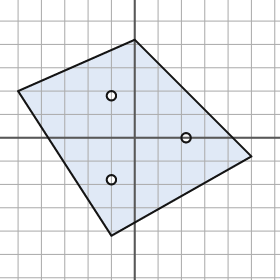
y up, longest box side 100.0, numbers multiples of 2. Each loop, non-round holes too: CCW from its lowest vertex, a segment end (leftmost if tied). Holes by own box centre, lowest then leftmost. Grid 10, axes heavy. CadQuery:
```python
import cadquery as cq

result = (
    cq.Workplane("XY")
    .moveTo(-10.0, -42.0)
    .lineTo(50.0, -8.0)
    .lineTo(0.0, 42.0)
    .lineTo(-50.0, 20.0)
    .close()
    .moveTo(-10.0, -18.0)
    .circle(2.0)
    .moveTo(22.0, 0.0)
    .circle(2.0)
    .moveTo(-10.0, 18.0)
    .circle(2.0)
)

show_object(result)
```